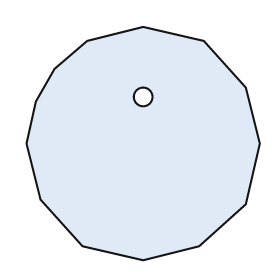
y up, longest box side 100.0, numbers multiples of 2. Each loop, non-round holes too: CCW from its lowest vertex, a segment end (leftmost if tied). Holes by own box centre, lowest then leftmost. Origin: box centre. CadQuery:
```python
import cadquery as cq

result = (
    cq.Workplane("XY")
    .moveTo(0.0, -50.0)
    .lineTo(24.0, -44.0)
    .lineTo(44.0, -26.0)
    .lineTo(50.0, 0.0)
    .lineTo(44.0, 24.0)
    .lineTo(26.0, 44.0)
    .lineTo(0.0, 50.0)
    .lineTo(-24.0, 44.0)
    .lineTo(-38.0, 32.0)
    .lineTo(-46.0, 18.0)
    .lineTo(-50.0, 0.0)
    .lineTo(-44.0, -24.0)
    .lineTo(-26.0, -44.0)
    .close()
    .moveTo(0.0, 20.0)
    .circle(4.0)
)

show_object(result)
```